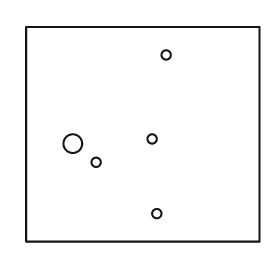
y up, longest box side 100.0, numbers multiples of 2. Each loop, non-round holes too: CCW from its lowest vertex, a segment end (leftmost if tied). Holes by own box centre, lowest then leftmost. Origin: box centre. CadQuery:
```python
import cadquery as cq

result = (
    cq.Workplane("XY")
    .moveTo(-50.0, -46.0)
    .lineTo(50.0, -46.0)
    .lineTo(50.0, 46.0)
    .lineTo(-50.0, 46.0)
    .close()
    .moveTo(6.0, -34.0)
    .circle(2.0)
    .moveTo(-20.0, -12.0)
    .circle(2.0)
    .moveTo(-30.0, -4.0)
    .circle(4.0)
    .moveTo(4.0, -2.0)
    .circle(2.0)
    .moveTo(10.0, 34.0)
    .circle(2.0)
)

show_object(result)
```